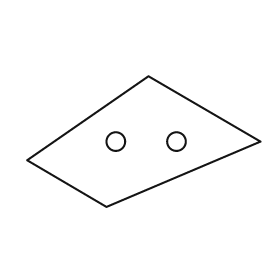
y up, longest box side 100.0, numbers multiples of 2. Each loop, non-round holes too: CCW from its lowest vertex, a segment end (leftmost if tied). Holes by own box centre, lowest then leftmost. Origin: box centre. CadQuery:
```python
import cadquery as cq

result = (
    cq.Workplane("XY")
    .moveTo(-16.0, -28.0)
    .lineTo(50.0, 0.0)
    .lineTo(2.0, 28.0)
    .lineTo(-50.0, -8.0)
    .close()
    .moveTo(-12.0, 0.0)
    .circle(4.0)
    .moveTo(14.0, 0.0)
    .circle(4.0)
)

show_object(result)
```